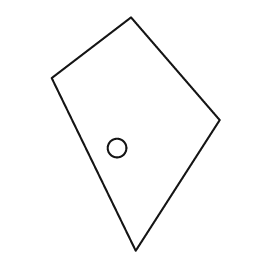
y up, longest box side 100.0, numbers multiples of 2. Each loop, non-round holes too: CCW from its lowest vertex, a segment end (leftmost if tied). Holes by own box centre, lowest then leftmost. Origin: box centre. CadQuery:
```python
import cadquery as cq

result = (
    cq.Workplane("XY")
    .moveTo(0.0, -50.0)
    .lineTo(36.0, 6.0)
    .lineTo(-2.0, 50.0)
    .lineTo(-36.0, 24.0)
    .close()
    .moveTo(-8.0, -6.0)
    .circle(4.0)
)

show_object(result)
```